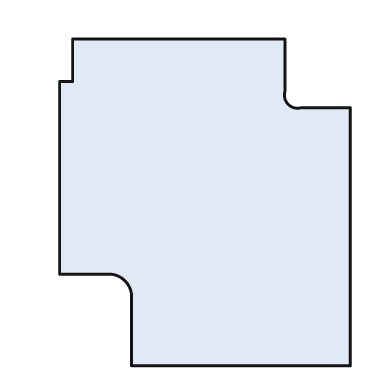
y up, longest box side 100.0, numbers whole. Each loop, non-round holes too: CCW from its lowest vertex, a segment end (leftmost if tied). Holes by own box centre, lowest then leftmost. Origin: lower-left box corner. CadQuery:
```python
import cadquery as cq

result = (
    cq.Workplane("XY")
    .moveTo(22.0, 0.0)
    .lineTo(89.0, 0.0)
    .lineTo(89.0, 79.0)
    .lineTo(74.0, 79.0)
    .threePointArc((70.0, 80.0), (69.0, 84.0))
    .lineTo(69.0, 100.0)
    .lineTo(4.0, 100.0)
    .lineTo(4.0, 87.0)
    .lineTo(0.0, 87.0)
    .lineTo(0.0, 28.0)
    .lineTo(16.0, 28.0)
    .threePointArc((20.0, 26.0), (22.0, 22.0))
    .close()
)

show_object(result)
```